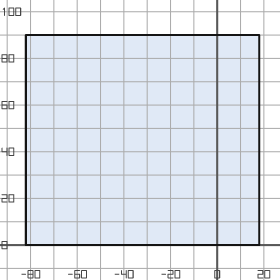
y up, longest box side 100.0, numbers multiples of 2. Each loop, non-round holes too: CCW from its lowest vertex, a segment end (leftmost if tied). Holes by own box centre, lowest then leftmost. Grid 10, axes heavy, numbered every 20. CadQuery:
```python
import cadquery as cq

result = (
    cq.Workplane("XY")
    .moveTo(-82.0, 0.0)
    .lineTo(18.0, 0.0)
    .lineTo(18.0, 90.0)
    .lineTo(-82.0, 90.0)
    .close()
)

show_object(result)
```